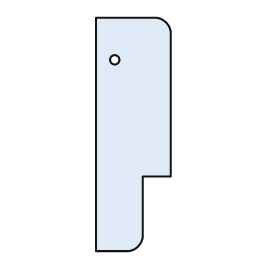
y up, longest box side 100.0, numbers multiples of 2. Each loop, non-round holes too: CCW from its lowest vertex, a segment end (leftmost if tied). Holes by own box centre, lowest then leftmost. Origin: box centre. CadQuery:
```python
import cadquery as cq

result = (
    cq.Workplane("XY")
    .moveTo(-16.0, -50.0)
    .lineTo(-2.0, -50.0)
    .threePointArc((2.0, -48.0), (4.0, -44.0))
    .lineTo(4.0, -18.0)
    .lineTo(16.0, -18.0)
    .lineTo(16.0, 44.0)
    .threePointArc((14.0, 48.0), (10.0, 50.0))
    .lineTo(-16.0, 50.0)
    .close()
    .moveTo(-8.0, 32.0)
    .circle(2.0)
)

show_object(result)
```